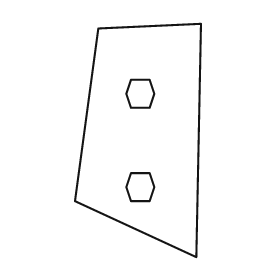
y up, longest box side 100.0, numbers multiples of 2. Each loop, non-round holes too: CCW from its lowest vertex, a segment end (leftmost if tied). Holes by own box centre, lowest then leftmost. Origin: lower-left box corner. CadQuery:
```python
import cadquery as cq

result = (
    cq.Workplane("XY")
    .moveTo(52.0, 0.0)
    .lineTo(54.0, 100.0)
    .lineTo(10.0, 98.0)
    .lineTo(0.0, 24.0)
    .close()
    .moveTo(24.0, 24.0)
    .lineTo(32.0, 24.0)
    .lineTo(34.0, 30.0)
    .lineTo(32.0, 36.0)
    .lineTo(24.0, 36.0)
    .lineTo(22.0, 30.0)
    .close()
    .moveTo(24.0, 64.0)
    .lineTo(32.0, 64.0)
    .lineTo(34.0, 70.0)
    .lineTo(32.0, 76.0)
    .lineTo(24.0, 76.0)
    .lineTo(22.0, 70.0)
    .close()
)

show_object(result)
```